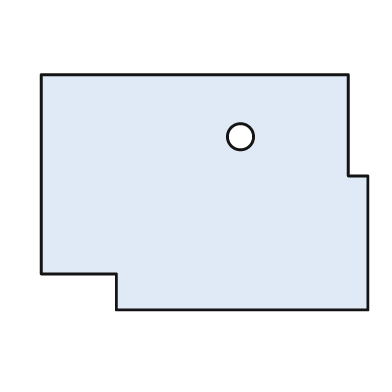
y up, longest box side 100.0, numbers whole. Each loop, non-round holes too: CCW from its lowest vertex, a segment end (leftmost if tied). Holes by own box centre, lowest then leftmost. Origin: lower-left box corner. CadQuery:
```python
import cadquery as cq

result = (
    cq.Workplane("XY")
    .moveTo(23.0, 0.0)
    .lineTo(100.0, 0.0)
    .lineTo(100.0, 41.0)
    .lineTo(94.0, 41.0)
    .lineTo(94.0, 72.0)
    .lineTo(0.0, 72.0)
    .lineTo(0.0, 11.0)
    .lineTo(23.0, 11.0)
    .close()
    .moveTo(61.0, 53.0)
    .circle(4.0)
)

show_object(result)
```